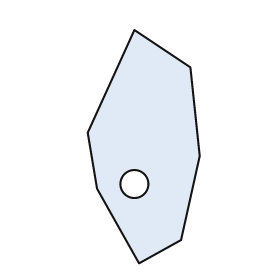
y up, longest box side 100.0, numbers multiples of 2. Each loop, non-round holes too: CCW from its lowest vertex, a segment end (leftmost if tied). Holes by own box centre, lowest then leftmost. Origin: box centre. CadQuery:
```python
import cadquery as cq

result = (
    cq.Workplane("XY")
    .moveTo(-2.0, -50.0)
    .lineTo(16.0, -40.0)
    .lineTo(24.0, -4.0)
    .lineTo(20.0, 34.0)
    .lineTo(-4.0, 50.0)
    .lineTo(-24.0, 6.0)
    .lineTo(-20.0, -18.0)
    .close()
    .moveTo(-4.0, -16.0)
    .circle(6.0)
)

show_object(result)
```